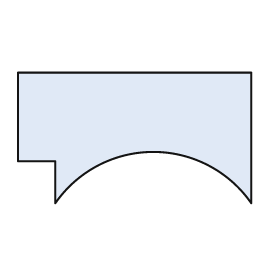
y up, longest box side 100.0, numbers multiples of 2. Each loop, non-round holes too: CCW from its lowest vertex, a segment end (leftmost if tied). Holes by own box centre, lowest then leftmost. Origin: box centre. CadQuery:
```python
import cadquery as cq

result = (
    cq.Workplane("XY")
    .moveTo(-34.0, -28.0)
    .threePointArc((8.0, -6.0), (50.0, -28.0))
    .lineTo(50.0, 28.0)
    .lineTo(-50.0, 28.0)
    .lineTo(-50.0, -10.0)
    .lineTo(-34.0, -10.0)
    .close()
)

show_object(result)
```